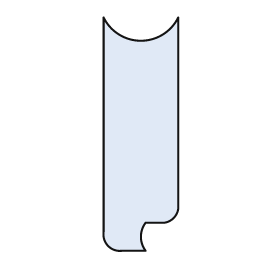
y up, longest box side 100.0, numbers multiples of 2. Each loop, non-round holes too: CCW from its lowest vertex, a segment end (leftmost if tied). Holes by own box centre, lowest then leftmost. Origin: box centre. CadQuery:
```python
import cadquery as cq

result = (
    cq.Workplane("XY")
    .moveTo(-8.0, -50.0)
    .lineTo(2.0, -50.0)
    .threePointArc((0.0, -44.0), (2.0, -38.0))
    .lineTo(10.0, -38.0)
    .threePointArc((14.0, -36.0), (16.0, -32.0))
    .lineTo(16.0, 50.0)
    .threePointArc((0.0, 40.0), (-16.0, 50.0))
    .lineTo(-16.0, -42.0)
    .threePointArc((-14.0, -48.0), (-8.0, -50.0))
    .close()
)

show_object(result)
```